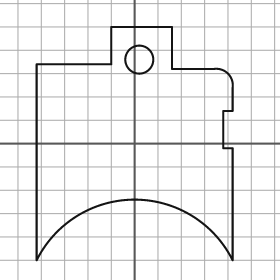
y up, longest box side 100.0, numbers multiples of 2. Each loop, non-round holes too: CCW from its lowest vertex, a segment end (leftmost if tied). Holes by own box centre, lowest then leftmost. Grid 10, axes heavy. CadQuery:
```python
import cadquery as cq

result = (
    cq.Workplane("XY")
    .moveTo(-42.0, -50.0)
    .threePointArc((0.0, -24.0), (42.0, -50.0))
    .lineTo(42.0, -2.0)
    .lineTo(38.0, -2.0)
    .lineTo(38.0, 14.0)
    .lineTo(42.0, 14.0)
    .lineTo(42.0, 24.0)
    .threePointArc((40.0, 30.0), (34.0, 32.0))
    .lineTo(16.0, 32.0)
    .lineTo(16.0, 50.0)
    .lineTo(-10.0, 50.0)
    .lineTo(-10.0, 34.0)
    .lineTo(-42.0, 34.0)
    .close()
    .moveTo(2.0, 36.0)
    .circle(6.0)
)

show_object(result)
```